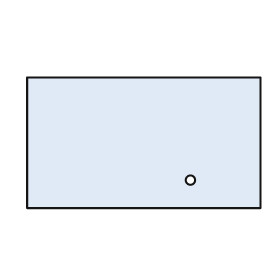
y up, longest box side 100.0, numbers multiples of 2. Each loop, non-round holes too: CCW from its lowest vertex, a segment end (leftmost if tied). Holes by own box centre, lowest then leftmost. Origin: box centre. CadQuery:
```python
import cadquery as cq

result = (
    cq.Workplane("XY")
    .moveTo(-50.0, -28.0)
    .lineTo(50.0, -28.0)
    .lineTo(50.0, 28.0)
    .lineTo(-50.0, 28.0)
    .close()
    .moveTo(20.0, -16.0)
    .circle(2.0)
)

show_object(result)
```